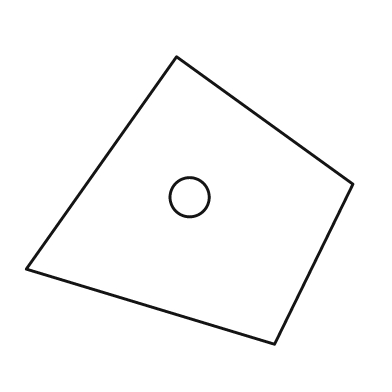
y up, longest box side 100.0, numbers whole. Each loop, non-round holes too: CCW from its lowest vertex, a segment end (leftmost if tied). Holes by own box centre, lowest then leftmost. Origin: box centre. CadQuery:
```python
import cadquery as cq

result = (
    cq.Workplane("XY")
    .moveTo(26.0, -44.0)
    .lineTo(50.0, 5.0)
    .lineTo(-4.0, 44.0)
    .lineTo(-50.0, -21.0)
    .close()
    .moveTo(0.0, 1.0)
    .circle(6.0)
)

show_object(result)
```